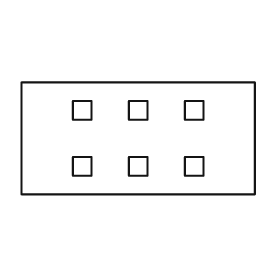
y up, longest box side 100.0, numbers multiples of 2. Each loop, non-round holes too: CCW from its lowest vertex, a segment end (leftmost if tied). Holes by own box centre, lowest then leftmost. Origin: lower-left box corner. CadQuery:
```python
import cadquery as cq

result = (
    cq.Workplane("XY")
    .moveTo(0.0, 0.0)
    .lineTo(100.0, 0.0)
    .lineTo(100.0, 48.0)
    .lineTo(0.0, 48.0)
    .close()
    .moveTo(22.0, 8.0)
    .lineTo(30.0, 8.0)
    .lineTo(30.0, 16.0)
    .lineTo(22.0, 16.0)
    .close()
    .moveTo(46.0, 8.0)
    .lineTo(54.0, 8.0)
    .lineTo(54.0, 16.0)
    .lineTo(46.0, 16.0)
    .close()
    .moveTo(70.0, 8.0)
    .lineTo(78.0, 8.0)
    .lineTo(78.0, 16.0)
    .lineTo(70.0, 16.0)
    .close()
    .moveTo(22.0, 32.0)
    .lineTo(30.0, 32.0)
    .lineTo(30.0, 40.0)
    .lineTo(22.0, 40.0)
    .close()
    .moveTo(46.0, 32.0)
    .lineTo(54.0, 32.0)
    .lineTo(54.0, 40.0)
    .lineTo(46.0, 40.0)
    .close()
    .moveTo(70.0, 32.0)
    .lineTo(78.0, 32.0)
    .lineTo(78.0, 40.0)
    .lineTo(70.0, 40.0)
    .close()
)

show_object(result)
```